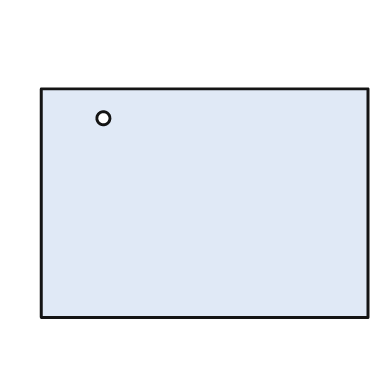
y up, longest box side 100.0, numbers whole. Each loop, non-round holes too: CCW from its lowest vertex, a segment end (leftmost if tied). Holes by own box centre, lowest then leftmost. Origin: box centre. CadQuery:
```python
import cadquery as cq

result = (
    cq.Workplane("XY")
    .moveTo(-50.0, -35.0)
    .lineTo(50.0, -35.0)
    .lineTo(50.0, 35.0)
    .lineTo(-50.0, 35.0)
    .close()
    .moveTo(-31.0, 26.0)
    .circle(2.0)
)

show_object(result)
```